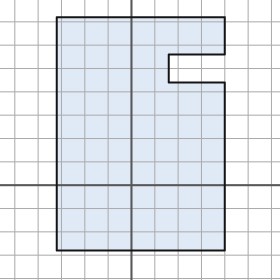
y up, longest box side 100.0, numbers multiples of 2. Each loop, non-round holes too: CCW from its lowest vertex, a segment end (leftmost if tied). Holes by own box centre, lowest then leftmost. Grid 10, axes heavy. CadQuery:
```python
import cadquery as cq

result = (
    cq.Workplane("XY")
    .moveTo(-32.0, -28.0)
    .lineTo(40.0, -28.0)
    .lineTo(40.0, 44.0)
    .lineTo(16.0, 44.0)
    .lineTo(16.0, 56.0)
    .lineTo(40.0, 56.0)
    .lineTo(40.0, 72.0)
    .lineTo(-32.0, 72.0)
    .close()
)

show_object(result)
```